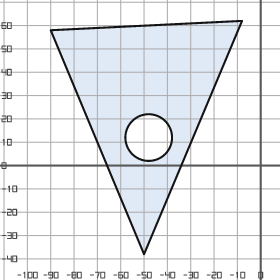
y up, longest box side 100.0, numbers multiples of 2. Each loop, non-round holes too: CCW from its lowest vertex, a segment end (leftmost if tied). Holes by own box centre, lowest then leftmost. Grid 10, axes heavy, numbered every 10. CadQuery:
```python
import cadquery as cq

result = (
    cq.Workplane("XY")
    .moveTo(-50.0, -38.0)
    .lineTo(-8.0, 62.0)
    .lineTo(-90.0, 58.0)
    .close()
    .moveTo(-48.0, 12.0)
    .circle(10.0)
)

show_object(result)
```